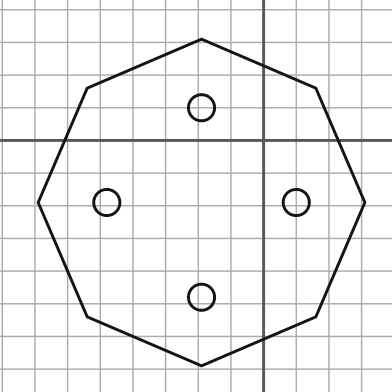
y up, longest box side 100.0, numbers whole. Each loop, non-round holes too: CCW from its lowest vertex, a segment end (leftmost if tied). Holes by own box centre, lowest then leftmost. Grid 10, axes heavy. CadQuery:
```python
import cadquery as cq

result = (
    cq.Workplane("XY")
    .moveTo(-19.0, -69.0)
    .lineTo(16.0, -54.0)
    .lineTo(31.0, -19.0)
    .lineTo(16.0, 16.0)
    .lineTo(-19.0, 31.0)
    .lineTo(-54.0, 16.0)
    .lineTo(-69.0, -19.0)
    .lineTo(-54.0, -54.0)
    .close()
    .moveTo(-19.0, -48.0)
    .circle(4.0)
    .moveTo(-48.0, -19.0)
    .circle(4.0)
    .moveTo(10.0, -19.0)
    .circle(4.0)
    .moveTo(-19.0, 10.0)
    .circle(4.0)
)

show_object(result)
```